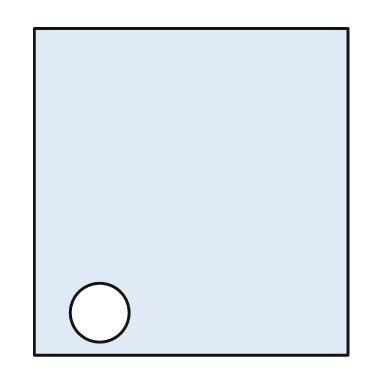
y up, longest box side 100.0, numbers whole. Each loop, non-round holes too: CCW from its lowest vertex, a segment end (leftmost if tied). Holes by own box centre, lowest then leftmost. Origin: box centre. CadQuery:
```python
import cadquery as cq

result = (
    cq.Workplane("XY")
    .moveTo(-48.0, -50.0)
    .lineTo(48.0, -50.0)
    .lineTo(48.0, 50.0)
    .lineTo(-48.0, 50.0)
    .close()
    .moveTo(-28.0, -37.0)
    .circle(9.0)
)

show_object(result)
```